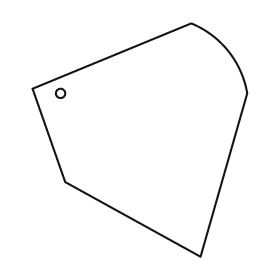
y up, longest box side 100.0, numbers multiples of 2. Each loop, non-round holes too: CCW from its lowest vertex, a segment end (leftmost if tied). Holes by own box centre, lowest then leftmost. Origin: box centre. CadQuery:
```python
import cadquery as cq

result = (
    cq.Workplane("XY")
    .moveTo(26.0, -50.0)
    .lineTo(46.0, 20.0)
    .threePointArc((38.0, 38.0), (22.0, 50.0))
    .lineTo(-46.0, 22.0)
    .lineTo(-32.0, -18.0)
    .close()
    .moveTo(-34.0, 20.0)
    .circle(2.0)
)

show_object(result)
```